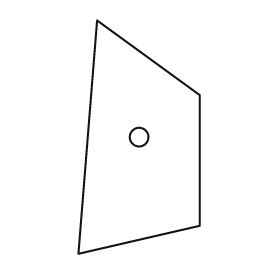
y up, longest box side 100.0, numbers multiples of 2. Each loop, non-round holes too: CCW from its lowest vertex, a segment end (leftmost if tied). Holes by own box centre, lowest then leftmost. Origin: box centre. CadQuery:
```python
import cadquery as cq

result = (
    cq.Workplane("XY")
    .moveTo(-26.0, -50.0)
    .lineTo(26.0, -38.0)
    .lineTo(26.0, 18.0)
    .lineTo(-18.0, 50.0)
    .close()
    .moveTo(0.0, 0.0)
    .circle(4.0)
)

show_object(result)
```